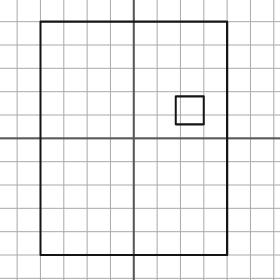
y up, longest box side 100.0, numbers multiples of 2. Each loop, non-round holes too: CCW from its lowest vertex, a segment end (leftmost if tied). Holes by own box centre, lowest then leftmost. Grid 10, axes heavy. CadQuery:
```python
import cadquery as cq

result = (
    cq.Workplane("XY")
    .moveTo(-40.0, -50.0)
    .lineTo(40.0, -50.0)
    .lineTo(40.0, 50.0)
    .lineTo(-40.0, 50.0)
    .close()
    .moveTo(18.0, 6.0)
    .lineTo(30.0, 6.0)
    .lineTo(30.0, 18.0)
    .lineTo(18.0, 18.0)
    .close()
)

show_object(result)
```